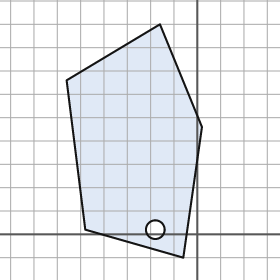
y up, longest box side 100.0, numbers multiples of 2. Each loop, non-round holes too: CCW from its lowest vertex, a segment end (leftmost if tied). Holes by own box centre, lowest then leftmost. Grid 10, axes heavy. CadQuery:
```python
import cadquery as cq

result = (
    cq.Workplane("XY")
    .moveTo(-6.0, -10.0)
    .lineTo(2.0, 46.0)
    .lineTo(-16.0, 90.0)
    .lineTo(-56.0, 66.0)
    .lineTo(-48.0, 2.0)
    .close()
    .moveTo(-18.0, 2.0)
    .circle(4.0)
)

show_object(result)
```